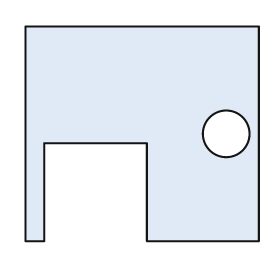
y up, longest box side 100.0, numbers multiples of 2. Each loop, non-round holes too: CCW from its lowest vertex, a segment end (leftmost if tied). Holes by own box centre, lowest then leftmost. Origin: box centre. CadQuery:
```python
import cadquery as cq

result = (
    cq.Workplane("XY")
    .moveTo(-50.0, -46.0)
    .lineTo(-42.0, -46.0)
    .lineTo(-42.0, -4.0)
    .lineTo(2.0, -4.0)
    .lineTo(2.0, -46.0)
    .lineTo(50.0, -46.0)
    .lineTo(50.0, 46.0)
    .lineTo(-50.0, 46.0)
    .close()
    .moveTo(36.0, 0.0)
    .circle(10.0)
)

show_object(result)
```